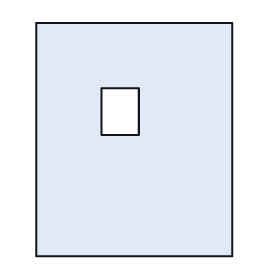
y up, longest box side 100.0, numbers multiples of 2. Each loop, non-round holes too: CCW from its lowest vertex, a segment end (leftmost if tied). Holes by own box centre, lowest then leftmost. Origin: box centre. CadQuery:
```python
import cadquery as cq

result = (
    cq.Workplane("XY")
    .moveTo(-42.0, -50.0)
    .lineTo(42.0, -50.0)
    .lineTo(42.0, 50.0)
    .lineTo(-42.0, 50.0)
    .close()
    .moveTo(-14.0, 2.0)
    .lineTo(2.0, 2.0)
    .lineTo(2.0, 22.0)
    .lineTo(-14.0, 22.0)
    .close()
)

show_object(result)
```